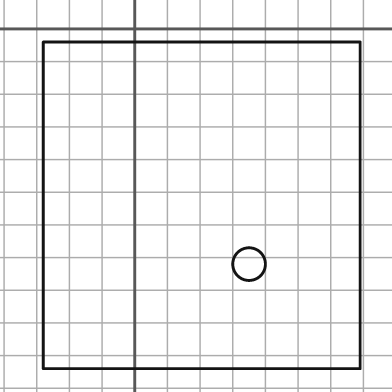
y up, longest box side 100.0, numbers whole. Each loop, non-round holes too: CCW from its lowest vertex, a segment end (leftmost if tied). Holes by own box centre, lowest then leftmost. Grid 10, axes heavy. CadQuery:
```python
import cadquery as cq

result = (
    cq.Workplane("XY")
    .moveTo(-28.0, -104.0)
    .lineTo(69.0, -104.0)
    .lineTo(69.0, -4.0)
    .lineTo(-28.0, -4.0)
    .close()
    .moveTo(35.0, -72.0)
    .circle(5.0)
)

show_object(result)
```